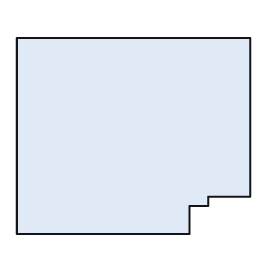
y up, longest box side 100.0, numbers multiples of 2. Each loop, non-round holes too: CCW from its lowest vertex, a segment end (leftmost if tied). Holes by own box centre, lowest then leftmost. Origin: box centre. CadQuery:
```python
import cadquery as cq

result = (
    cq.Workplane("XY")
    .moveTo(-50.0, -42.0)
    .lineTo(24.0, -42.0)
    .lineTo(24.0, -30.0)
    .lineTo(32.0, -30.0)
    .lineTo(32.0, -26.0)
    .lineTo(50.0, -26.0)
    .lineTo(50.0, 42.0)
    .lineTo(-50.0, 42.0)
    .close()
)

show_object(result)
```